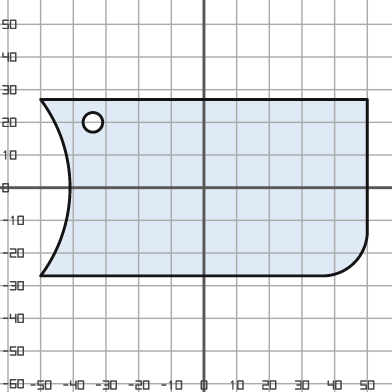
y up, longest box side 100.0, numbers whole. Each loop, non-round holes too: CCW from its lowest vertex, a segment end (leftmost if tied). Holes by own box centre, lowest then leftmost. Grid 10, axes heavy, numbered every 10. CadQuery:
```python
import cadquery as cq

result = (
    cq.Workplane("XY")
    .moveTo(-50.0, -27.0)
    .lineTo(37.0, -27.0)
    .threePointArc((46.0, -23.0), (50.0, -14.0))
    .lineTo(50.0, 27.0)
    .lineTo(-50.0, 27.0)
    .threePointArc((-41.0, 0.0), (-50.0, -27.0))
    .close()
    .moveTo(-34.0, 20.0)
    .circle(3.0)
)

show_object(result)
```